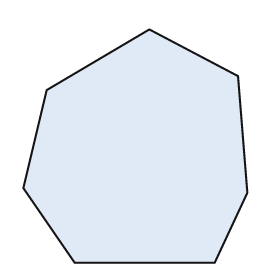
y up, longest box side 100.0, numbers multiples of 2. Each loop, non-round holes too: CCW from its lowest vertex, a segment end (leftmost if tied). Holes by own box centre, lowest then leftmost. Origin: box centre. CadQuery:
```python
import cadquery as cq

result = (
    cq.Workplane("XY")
    .moveTo(-26.0, -50.0)
    .lineTo(34.0, -50.0)
    .lineTo(48.0, -20.0)
    .lineTo(44.0, 30.0)
    .lineTo(6.0, 50.0)
    .lineTo(-38.0, 24.0)
    .lineTo(-48.0, -18.0)
    .close()
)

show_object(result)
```